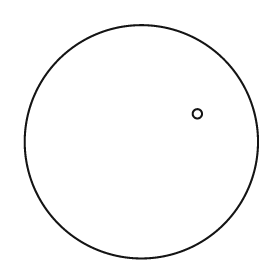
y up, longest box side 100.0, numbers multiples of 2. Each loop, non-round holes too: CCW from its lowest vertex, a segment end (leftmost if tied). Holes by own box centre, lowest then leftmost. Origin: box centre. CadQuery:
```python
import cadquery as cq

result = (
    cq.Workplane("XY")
    .moveTo(0.0, 0.0)
    .circle(50.0)
    .moveTo(24.0, 12.0)
    .circle(2.0)
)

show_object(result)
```